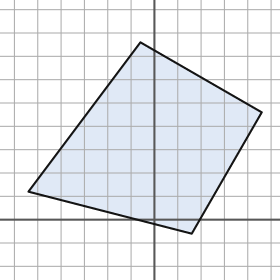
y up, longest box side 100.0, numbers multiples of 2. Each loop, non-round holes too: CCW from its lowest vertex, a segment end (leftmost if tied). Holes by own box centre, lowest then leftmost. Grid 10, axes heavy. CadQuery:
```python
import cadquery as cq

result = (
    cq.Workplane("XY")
    .moveTo(16.0, -6.0)
    .lineTo(46.0, 46.0)
    .lineTo(-6.0, 76.0)
    .lineTo(-54.0, 12.0)
    .close()
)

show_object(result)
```